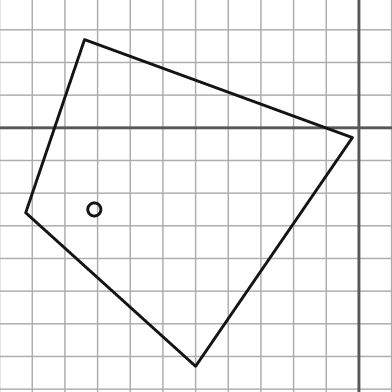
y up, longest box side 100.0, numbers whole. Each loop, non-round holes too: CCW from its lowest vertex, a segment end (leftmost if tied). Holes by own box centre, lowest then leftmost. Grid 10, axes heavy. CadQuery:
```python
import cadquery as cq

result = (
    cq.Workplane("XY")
    .moveTo(-50.0, -73.0)
    .lineTo(-2.0, -3.0)
    .lineTo(-84.0, 27.0)
    .lineTo(-102.0, -26.0)
    .close()
    .moveTo(-81.0, -25.0)
    .circle(2.0)
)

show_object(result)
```